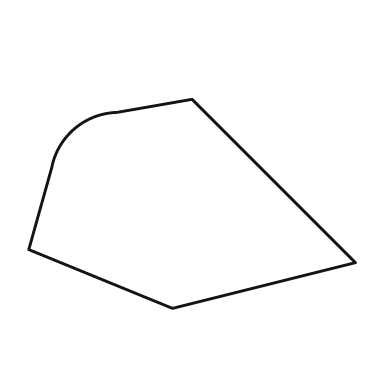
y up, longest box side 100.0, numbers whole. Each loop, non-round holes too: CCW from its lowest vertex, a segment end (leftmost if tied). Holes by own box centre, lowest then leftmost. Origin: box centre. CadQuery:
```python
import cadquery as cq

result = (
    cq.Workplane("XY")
    .moveTo(-6.0, -32.0)
    .lineTo(50.0, -18.0)
    .lineTo(0.0, 32.0)
    .lineTo(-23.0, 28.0)
    .threePointArc((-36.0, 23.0), (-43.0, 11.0))
    .lineTo(-50.0, -14.0)
    .close()
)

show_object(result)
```